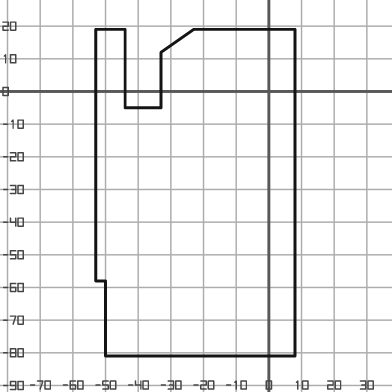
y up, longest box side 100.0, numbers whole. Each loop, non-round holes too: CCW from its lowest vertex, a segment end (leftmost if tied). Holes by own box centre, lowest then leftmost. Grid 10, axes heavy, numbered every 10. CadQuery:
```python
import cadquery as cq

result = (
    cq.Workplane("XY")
    .moveTo(-50.0, -81.0)
    .lineTo(8.0, -81.0)
    .lineTo(8.0, 19.0)
    .lineTo(-23.0, 19.0)
    .lineTo(-33.0, 12.0)
    .lineTo(-33.0, -5.0)
    .lineTo(-44.0, -5.0)
    .lineTo(-44.0, 19.0)
    .lineTo(-53.0, 19.0)
    .lineTo(-53.0, -58.0)
    .lineTo(-50.0, -58.0)
    .close()
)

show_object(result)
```